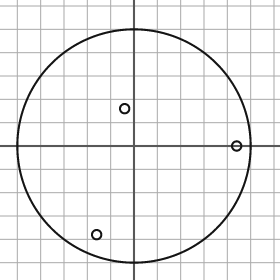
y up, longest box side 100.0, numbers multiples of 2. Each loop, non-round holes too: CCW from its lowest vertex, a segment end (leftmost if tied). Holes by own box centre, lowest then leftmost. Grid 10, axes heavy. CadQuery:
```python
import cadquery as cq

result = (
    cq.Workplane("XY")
    .moveTo(0.0, 0.0)
    .circle(50.0)
    .moveTo(-16.0, -38.0)
    .circle(2.0)
    .moveTo(44.0, 0.0)
    .circle(2.0)
    .moveTo(-4.0, 16.0)
    .circle(2.0)
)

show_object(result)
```